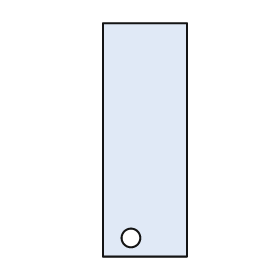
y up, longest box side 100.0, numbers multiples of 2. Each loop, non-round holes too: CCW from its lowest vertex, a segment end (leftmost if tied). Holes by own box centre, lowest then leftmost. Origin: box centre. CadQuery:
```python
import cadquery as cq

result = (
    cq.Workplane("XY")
    .moveTo(-18.0, -50.0)
    .lineTo(18.0, -50.0)
    .lineTo(18.0, 50.0)
    .lineTo(-18.0, 50.0)
    .close()
    .moveTo(-6.0, -42.0)
    .circle(4.0)
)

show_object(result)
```